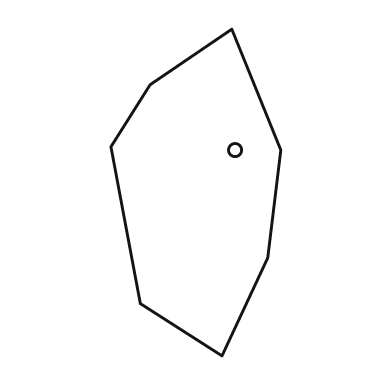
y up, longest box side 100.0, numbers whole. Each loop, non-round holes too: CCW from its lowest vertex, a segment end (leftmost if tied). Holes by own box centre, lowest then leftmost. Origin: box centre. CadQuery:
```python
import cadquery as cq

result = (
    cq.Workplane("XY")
    .moveTo(8.0, -50.0)
    .lineTo(22.0, -20.0)
    .lineTo(26.0, 13.0)
    .lineTo(11.0, 50.0)
    .lineTo(-14.0, 33.0)
    .lineTo(-26.0, 14.0)
    .lineTo(-17.0, -34.0)
    .close()
    .moveTo(12.0, 13.0)
    .circle(2.0)
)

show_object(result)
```